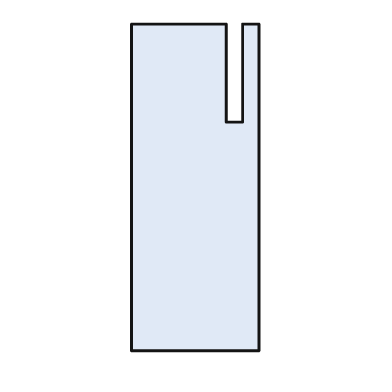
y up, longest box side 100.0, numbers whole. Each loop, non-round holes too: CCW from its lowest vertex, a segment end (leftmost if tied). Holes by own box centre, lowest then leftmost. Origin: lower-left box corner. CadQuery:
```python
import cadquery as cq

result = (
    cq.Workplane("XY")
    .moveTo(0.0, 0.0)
    .lineTo(39.0, 0.0)
    .lineTo(39.0, 100.0)
    .lineTo(34.0, 100.0)
    .lineTo(34.0, 70.0)
    .lineTo(29.0, 70.0)
    .lineTo(29.0, 100.0)
    .lineTo(0.0, 100.0)
    .close()
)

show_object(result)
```